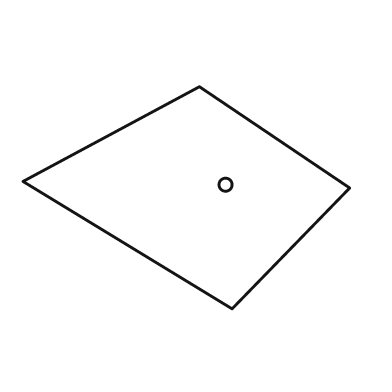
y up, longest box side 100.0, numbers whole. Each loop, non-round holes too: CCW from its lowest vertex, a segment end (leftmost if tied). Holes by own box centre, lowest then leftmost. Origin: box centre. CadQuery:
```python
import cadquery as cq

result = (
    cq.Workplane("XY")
    .moveTo(14.0, -34.0)
    .lineTo(50.0, 3.0)
    .lineTo(4.0, 34.0)
    .lineTo(-50.0, 5.0)
    .close()
    .moveTo(12.0, 4.0)
    .circle(2.0)
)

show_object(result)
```